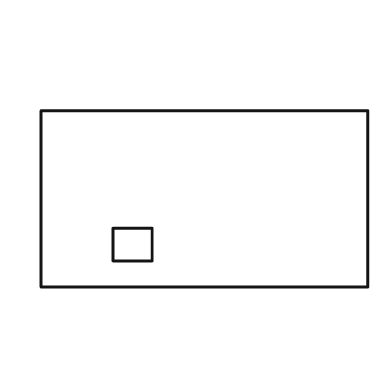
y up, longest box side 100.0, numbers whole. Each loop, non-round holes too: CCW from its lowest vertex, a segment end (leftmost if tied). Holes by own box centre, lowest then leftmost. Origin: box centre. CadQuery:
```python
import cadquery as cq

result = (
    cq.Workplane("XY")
    .moveTo(-50.0, -27.0)
    .lineTo(50.0, -27.0)
    .lineTo(50.0, 27.0)
    .lineTo(-50.0, 27.0)
    .close()
    .moveTo(-28.0, -19.0)
    .lineTo(-16.0, -19.0)
    .lineTo(-16.0, -9.0)
    .lineTo(-28.0, -9.0)
    .close()
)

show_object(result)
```